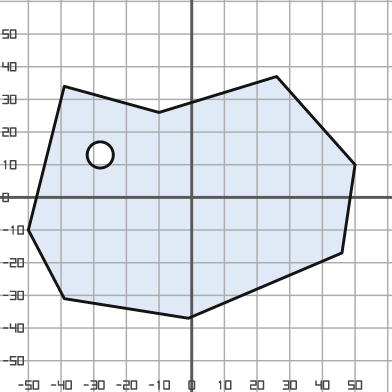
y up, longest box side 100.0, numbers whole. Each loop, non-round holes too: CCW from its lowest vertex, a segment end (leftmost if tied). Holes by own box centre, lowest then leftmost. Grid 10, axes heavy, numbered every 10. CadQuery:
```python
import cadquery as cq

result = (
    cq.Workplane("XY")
    .moveTo(-1.0, -37.0)
    .lineTo(46.0, -17.0)
    .lineTo(50.0, 10.0)
    .lineTo(26.0, 37.0)
    .lineTo(-10.0, 26.0)
    .lineTo(-39.0, 34.0)
    .lineTo(-50.0, -10.0)
    .lineTo(-39.0, -31.0)
    .close()
    .moveTo(-28.0, 13.0)
    .circle(4.0)
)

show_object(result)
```